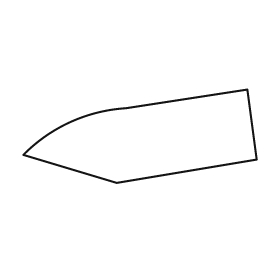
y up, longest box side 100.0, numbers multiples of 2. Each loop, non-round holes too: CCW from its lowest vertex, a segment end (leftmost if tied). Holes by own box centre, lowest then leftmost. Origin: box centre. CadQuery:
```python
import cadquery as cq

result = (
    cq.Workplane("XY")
    .moveTo(-10.0, -20.0)
    .lineTo(50.0, -10.0)
    .lineTo(46.0, 20.0)
    .lineTo(-6.0, 12.0)
    .threePointArc((-30.0, 6.0), (-50.0, -8.0))
    .close()
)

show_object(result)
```